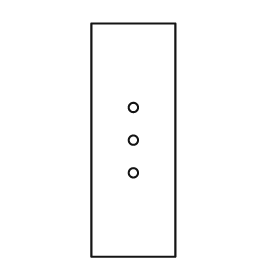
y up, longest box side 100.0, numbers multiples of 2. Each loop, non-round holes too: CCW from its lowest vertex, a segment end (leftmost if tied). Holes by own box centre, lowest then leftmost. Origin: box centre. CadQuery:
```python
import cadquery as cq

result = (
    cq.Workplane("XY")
    .moveTo(-18.0, -50.0)
    .lineTo(18.0, -50.0)
    .lineTo(18.0, 50.0)
    .lineTo(-18.0, 50.0)
    .close()
    .moveTo(0.0, -14.0)
    .circle(2.0)
    .moveTo(0.0, 0.0)
    .circle(2.0)
    .moveTo(0.0, 14.0)
    .circle(2.0)
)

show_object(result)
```